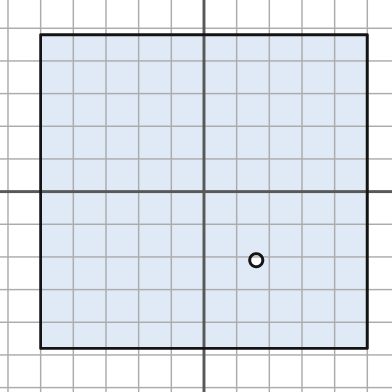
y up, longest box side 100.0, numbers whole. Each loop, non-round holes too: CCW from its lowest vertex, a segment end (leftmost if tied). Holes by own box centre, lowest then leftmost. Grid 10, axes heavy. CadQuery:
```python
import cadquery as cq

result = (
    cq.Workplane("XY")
    .moveTo(-50.0, -48.0)
    .lineTo(50.0, -48.0)
    .lineTo(50.0, 48.0)
    .lineTo(-50.0, 48.0)
    .close()
    .moveTo(16.0, -21.0)
    .circle(2.0)
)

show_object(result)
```